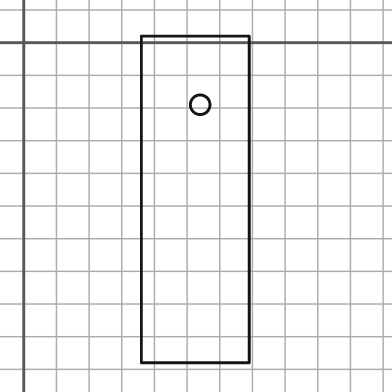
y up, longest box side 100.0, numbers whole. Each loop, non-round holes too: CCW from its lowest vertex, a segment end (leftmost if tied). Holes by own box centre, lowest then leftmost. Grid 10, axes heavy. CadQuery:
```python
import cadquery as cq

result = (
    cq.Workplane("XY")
    .moveTo(36.0, -98.0)
    .lineTo(69.0, -98.0)
    .lineTo(69.0, 2.0)
    .lineTo(36.0, 2.0)
    .close()
    .moveTo(54.0, -19.0)
    .circle(3.0)
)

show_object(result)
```